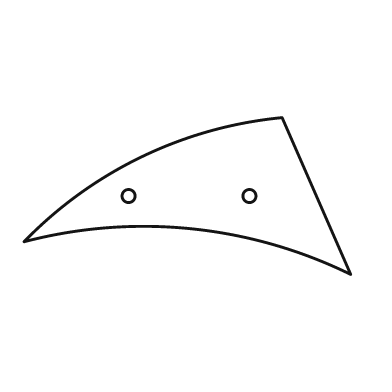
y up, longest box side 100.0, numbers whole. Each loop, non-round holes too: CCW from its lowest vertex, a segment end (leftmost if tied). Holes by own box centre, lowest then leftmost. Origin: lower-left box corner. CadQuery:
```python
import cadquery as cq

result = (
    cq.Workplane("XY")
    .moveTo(100.0, 0.0)
    .lineTo(79.0, 48.0)
    .threePointArc((36.0, 36.0), (0.0, 10.0))
    .threePointArc((51.0, 14.0), (100.0, 0.0))
    .close()
    .moveTo(32.0, 24.0)
    .circle(2.0)
    .moveTo(69.0, 24.0)
    .circle(2.0)
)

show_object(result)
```